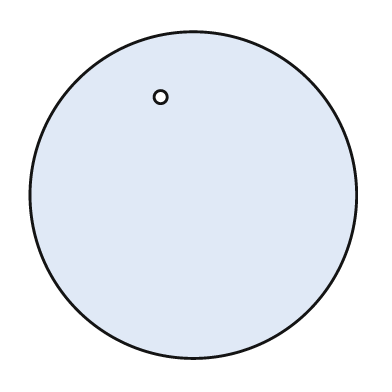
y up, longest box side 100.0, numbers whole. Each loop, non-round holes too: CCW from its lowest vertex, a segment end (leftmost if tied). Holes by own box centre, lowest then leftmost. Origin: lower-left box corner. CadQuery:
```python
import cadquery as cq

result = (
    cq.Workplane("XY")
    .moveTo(50.0, 50.0)
    .circle(50.0)
    .moveTo(40.0, 80.0)
    .circle(2.0)
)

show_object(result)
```